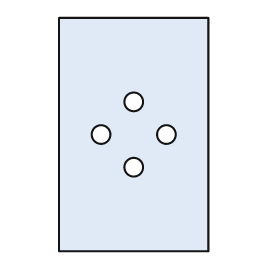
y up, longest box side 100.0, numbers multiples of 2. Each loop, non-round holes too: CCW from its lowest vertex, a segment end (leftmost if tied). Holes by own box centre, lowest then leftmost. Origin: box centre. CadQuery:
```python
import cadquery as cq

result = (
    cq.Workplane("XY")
    .moveTo(-32.0, -50.0)
    .lineTo(32.0, -50.0)
    .lineTo(32.0, 50.0)
    .lineTo(-32.0, 50.0)
    .close()
    .moveTo(0.0, -14.0)
    .circle(4.0)
    .moveTo(-14.0, 0.0)
    .circle(4.0)
    .moveTo(14.0, 0.0)
    .circle(4.0)
    .moveTo(0.0, 14.0)
    .circle(4.0)
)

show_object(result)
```